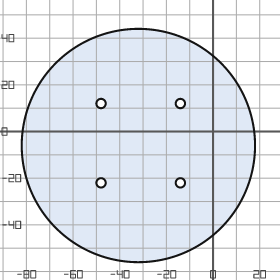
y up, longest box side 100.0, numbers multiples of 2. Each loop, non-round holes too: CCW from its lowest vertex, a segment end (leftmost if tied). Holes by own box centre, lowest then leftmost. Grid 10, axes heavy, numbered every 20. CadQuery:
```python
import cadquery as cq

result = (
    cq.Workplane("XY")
    .moveTo(-32.0, -6.0)
    .circle(50.0)
    .moveTo(-48.0, -22.0)
    .circle(2.0)
    .moveTo(-14.0, -22.0)
    .circle(2.0)
    .moveTo(-48.0, 12.0)
    .circle(2.0)
    .moveTo(-14.0, 12.0)
    .circle(2.0)
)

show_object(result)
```